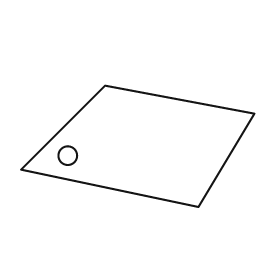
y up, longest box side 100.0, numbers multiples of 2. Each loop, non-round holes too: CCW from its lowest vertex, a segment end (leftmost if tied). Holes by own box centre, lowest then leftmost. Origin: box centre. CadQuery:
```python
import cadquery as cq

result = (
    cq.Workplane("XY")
    .moveTo(26.0, -26.0)
    .lineTo(50.0, 14.0)
    .lineTo(-14.0, 26.0)
    .lineTo(-50.0, -10.0)
    .close()
    .moveTo(-30.0, -4.0)
    .circle(4.0)
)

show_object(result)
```